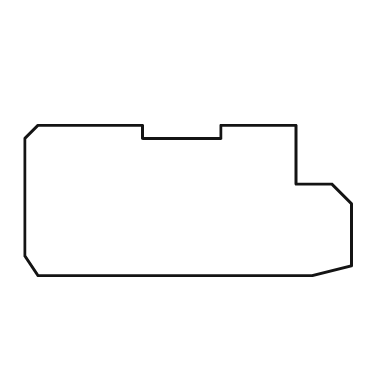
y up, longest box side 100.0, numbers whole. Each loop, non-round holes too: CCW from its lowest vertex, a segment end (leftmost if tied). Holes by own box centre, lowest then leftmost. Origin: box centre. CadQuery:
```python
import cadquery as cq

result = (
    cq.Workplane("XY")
    .moveTo(-46.0, -23.0)
    .lineTo(38.0, -23.0)
    .lineTo(50.0, -20.0)
    .lineTo(50.0, -1.0)
    .lineTo(44.0, 5.0)
    .lineTo(33.0, 5.0)
    .lineTo(33.0, 23.0)
    .lineTo(10.0, 23.0)
    .lineTo(10.0, 19.0)
    .lineTo(-14.0, 19.0)
    .lineTo(-14.0, 23.0)
    .lineTo(-46.0, 23.0)
    .lineTo(-50.0, 19.0)
    .lineTo(-50.0, -17.0)
    .close()
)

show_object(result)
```